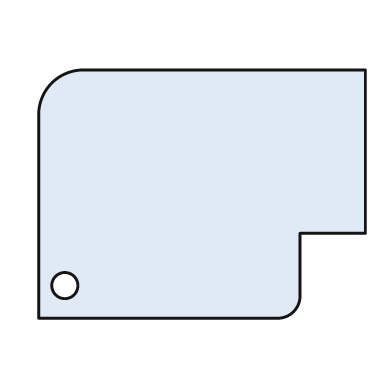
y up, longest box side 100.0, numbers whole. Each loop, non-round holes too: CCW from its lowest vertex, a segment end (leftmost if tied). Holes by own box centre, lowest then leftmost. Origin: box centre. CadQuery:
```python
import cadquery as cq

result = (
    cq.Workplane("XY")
    .moveTo(-50.0, -38.0)
    .lineTo(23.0, -38.0)
    .threePointArc((28.0, -36.0), (30.0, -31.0))
    .lineTo(30.0, -12.0)
    .lineTo(50.0, -12.0)
    .lineTo(50.0, 38.0)
    .lineTo(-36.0, 38.0)
    .threePointArc((-46.0, 34.0), (-50.0, 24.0))
    .close()
    .moveTo(-42.0, -28.0)
    .circle(4.0)
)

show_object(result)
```